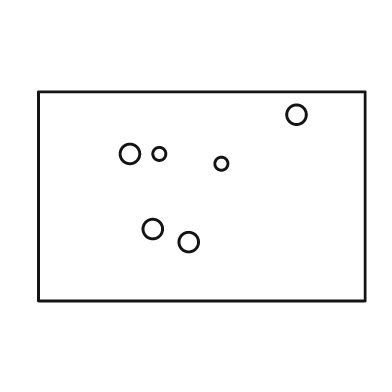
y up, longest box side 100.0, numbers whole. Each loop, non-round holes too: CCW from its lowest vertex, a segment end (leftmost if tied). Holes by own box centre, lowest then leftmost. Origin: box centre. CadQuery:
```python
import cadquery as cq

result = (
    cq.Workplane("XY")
    .moveTo(-50.0, -32.0)
    .lineTo(50.0, -32.0)
    .lineTo(50.0, 32.0)
    .lineTo(-50.0, 32.0)
    .close()
    .moveTo(-4.0, -14.0)
    .circle(3.0)
    .moveTo(-15.0, -10.0)
    .circle(3.0)
    .moveTo(6.0, 10.0)
    .circle(2.0)
    .moveTo(-22.0, 13.0)
    .circle(3.0)
    .moveTo(-13.0, 13.0)
    .circle(2.0)
    .moveTo(29.0, 25.0)
    .circle(3.0)
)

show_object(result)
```